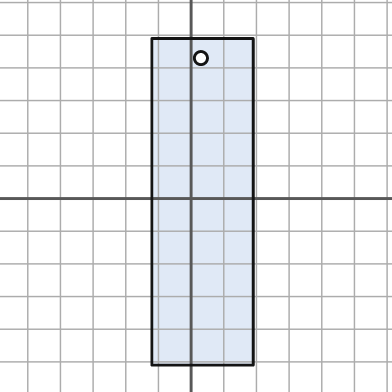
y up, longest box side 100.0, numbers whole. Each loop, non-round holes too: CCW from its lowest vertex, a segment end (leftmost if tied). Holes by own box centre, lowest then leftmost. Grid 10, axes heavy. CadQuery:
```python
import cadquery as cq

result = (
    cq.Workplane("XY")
    .moveTo(-12.0, -51.0)
    .lineTo(19.0, -51.0)
    .lineTo(19.0, 49.0)
    .lineTo(-12.0, 49.0)
    .close()
    .moveTo(3.0, 43.0)
    .circle(2.0)
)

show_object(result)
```